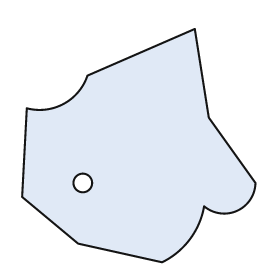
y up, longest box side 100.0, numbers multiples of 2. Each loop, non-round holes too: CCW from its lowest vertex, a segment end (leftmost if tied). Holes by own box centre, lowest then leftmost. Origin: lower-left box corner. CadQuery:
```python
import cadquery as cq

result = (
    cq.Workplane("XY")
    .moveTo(60.0, 0.0)
    .threePointArc((72.0, 10.0), (78.0, 24.0))
    .threePointArc((92.0, 22.0), (100.0, 34.0))
    .lineTo(80.0, 62.0)
    .lineTo(74.0, 100.0)
    .lineTo(28.0, 80.0)
    .threePointArc((18.0, 68.0), (2.0, 66.0))
    .lineTo(0.0, 28.0)
    .lineTo(24.0, 8.0)
    .close()
    .moveTo(26.0, 34.0)
    .circle(4.0)
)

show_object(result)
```